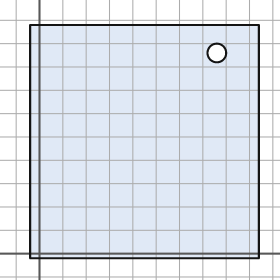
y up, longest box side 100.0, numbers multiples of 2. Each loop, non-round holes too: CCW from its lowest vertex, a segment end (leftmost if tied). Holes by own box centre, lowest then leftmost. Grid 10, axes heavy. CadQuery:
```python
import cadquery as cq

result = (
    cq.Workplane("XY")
    .moveTo(-4.0, -2.0)
    .lineTo(94.0, -2.0)
    .lineTo(94.0, 98.0)
    .lineTo(-4.0, 98.0)
    .close()
    .moveTo(76.0, 86.0)
    .circle(4.0)
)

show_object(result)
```